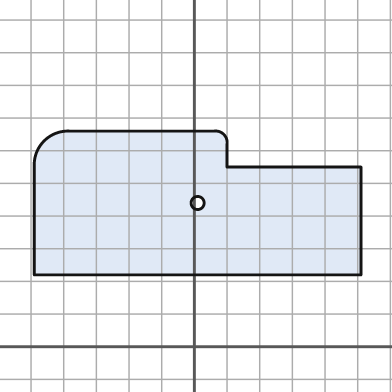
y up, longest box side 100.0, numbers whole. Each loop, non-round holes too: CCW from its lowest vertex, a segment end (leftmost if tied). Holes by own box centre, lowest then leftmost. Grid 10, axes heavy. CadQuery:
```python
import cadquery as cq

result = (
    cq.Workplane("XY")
    .moveTo(-49.0, 22.0)
    .lineTo(51.0, 22.0)
    .lineTo(51.0, 55.0)
    .lineTo(10.0, 55.0)
    .lineTo(10.0, 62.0)
    .threePointArc((9.0, 65.0), (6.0, 66.0))
    .lineTo(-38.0, 66.0)
    .threePointArc((-46.0, 63.0), (-49.0, 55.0))
    .close()
    .moveTo(1.0, 44.0)
    .circle(2.0)
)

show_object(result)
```